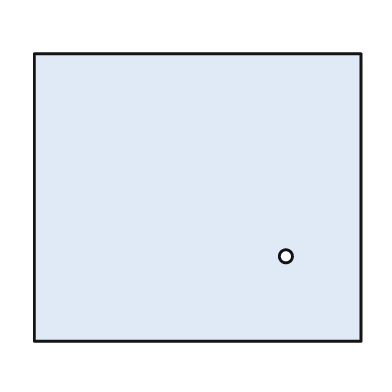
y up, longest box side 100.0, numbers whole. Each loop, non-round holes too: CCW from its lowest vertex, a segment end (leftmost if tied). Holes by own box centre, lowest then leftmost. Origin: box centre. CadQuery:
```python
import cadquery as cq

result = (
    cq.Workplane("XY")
    .moveTo(-50.0, -44.0)
    .lineTo(50.0, -44.0)
    .lineTo(50.0, 44.0)
    .lineTo(-50.0, 44.0)
    .close()
    .moveTo(27.0, -18.0)
    .circle(2.0)
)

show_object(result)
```